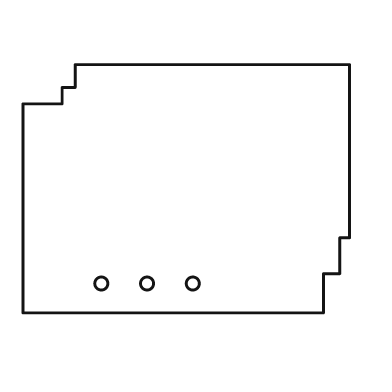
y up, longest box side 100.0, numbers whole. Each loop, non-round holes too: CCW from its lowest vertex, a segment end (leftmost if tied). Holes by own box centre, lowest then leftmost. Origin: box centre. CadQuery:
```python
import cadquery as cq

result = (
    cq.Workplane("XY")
    .moveTo(-50.0, -38.0)
    .lineTo(42.0, -38.0)
    .lineTo(42.0, -26.0)
    .lineTo(47.0, -26.0)
    .lineTo(47.0, -15.0)
    .lineTo(50.0, -15.0)
    .lineTo(50.0, 38.0)
    .lineTo(-34.0, 38.0)
    .lineTo(-34.0, 31.0)
    .lineTo(-38.0, 31.0)
    .lineTo(-38.0, 26.0)
    .lineTo(-50.0, 26.0)
    .close()
    .moveTo(-26.0, -29.0)
    .circle(2.0)
    .moveTo(-12.0, -29.0)
    .circle(2.0)
    .moveTo(2.0, -29.0)
    .circle(2.0)
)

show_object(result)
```